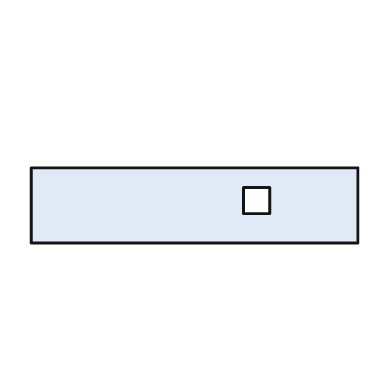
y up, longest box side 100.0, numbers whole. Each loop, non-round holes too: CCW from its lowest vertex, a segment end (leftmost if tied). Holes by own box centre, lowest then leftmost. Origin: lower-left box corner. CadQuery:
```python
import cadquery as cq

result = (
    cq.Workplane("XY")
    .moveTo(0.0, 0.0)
    .lineTo(100.0, 0.0)
    .lineTo(100.0, 23.0)
    .lineTo(0.0, 23.0)
    .close()
    .moveTo(65.0, 9.0)
    .lineTo(73.0, 9.0)
    .lineTo(73.0, 17.0)
    .lineTo(65.0, 17.0)
    .close()
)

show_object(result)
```